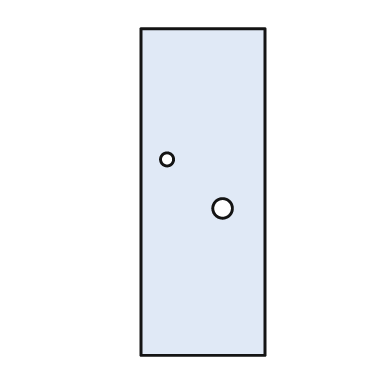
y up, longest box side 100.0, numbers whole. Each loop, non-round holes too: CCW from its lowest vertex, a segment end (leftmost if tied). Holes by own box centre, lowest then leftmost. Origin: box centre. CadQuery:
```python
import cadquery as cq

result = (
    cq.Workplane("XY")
    .moveTo(-19.0, -50.0)
    .lineTo(19.0, -50.0)
    .lineTo(19.0, 50.0)
    .lineTo(-19.0, 50.0)
    .close()
    .moveTo(6.0, -5.0)
    .circle(3.0)
    .moveTo(-11.0, 10.0)
    .circle(2.0)
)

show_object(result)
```